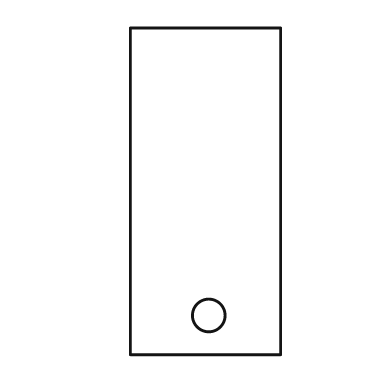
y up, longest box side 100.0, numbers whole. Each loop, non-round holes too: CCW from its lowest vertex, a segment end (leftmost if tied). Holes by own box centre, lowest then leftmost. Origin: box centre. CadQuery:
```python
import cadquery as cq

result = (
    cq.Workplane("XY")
    .moveTo(-23.0, -50.0)
    .lineTo(23.0, -50.0)
    .lineTo(23.0, 50.0)
    .lineTo(-23.0, 50.0)
    .close()
    .moveTo(1.0, -38.0)
    .circle(5.0)
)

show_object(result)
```